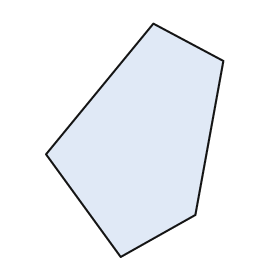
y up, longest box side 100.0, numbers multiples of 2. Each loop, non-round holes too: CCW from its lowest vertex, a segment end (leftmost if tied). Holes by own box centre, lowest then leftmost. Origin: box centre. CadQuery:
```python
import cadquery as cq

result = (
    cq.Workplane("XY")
    .moveTo(-6.0, -50.0)
    .lineTo(26.0, -32.0)
    .lineTo(38.0, 34.0)
    .lineTo(8.0, 50.0)
    .lineTo(-38.0, -6.0)
    .close()
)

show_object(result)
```